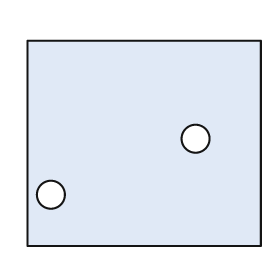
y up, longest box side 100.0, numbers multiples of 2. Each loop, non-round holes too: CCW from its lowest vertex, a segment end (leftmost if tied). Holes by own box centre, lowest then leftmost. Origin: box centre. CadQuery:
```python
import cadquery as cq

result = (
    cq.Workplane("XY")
    .moveTo(-50.0, -44.0)
    .lineTo(50.0, -44.0)
    .lineTo(50.0, 44.0)
    .lineTo(-50.0, 44.0)
    .close()
    .moveTo(-40.0, -22.0)
    .circle(6.0)
    .moveTo(22.0, 2.0)
    .circle(6.0)
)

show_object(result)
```